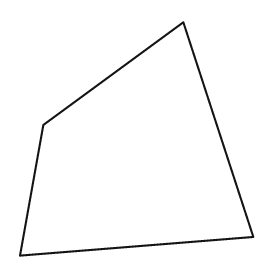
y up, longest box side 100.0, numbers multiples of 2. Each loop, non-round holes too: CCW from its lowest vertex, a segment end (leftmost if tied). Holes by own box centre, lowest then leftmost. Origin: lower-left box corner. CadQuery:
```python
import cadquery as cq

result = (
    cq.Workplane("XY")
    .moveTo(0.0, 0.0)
    .lineTo(100.0, 8.0)
    .lineTo(70.0, 100.0)
    .lineTo(10.0, 56.0)
    .close()
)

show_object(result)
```